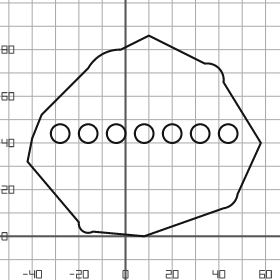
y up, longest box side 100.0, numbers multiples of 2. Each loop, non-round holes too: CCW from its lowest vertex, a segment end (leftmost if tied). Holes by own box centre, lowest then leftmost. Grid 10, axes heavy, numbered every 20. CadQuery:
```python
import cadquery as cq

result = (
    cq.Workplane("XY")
    .moveTo(8.0, 0.0)
    .lineTo(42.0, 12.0)
    .threePointArc((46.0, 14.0), (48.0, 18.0))
    .lineTo(58.0, 40.0)
    .lineTo(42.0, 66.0)
    .threePointArc((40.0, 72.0), (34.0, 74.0))
    .lineTo(10.0, 86.0)
    .lineTo(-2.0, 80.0)
    .threePointArc((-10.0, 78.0), (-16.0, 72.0))
    .lineTo(-36.0, 52.0)
    .lineTo(-40.0, 42.0)
    .lineTo(-42.0, 32.0)
    .lineTo(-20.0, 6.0)
    .threePointArc((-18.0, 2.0), (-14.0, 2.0))
    .close()
    .moveTo(-28.0, 44.0)
    .circle(4.0)
    .moveTo(-16.0, 44.0)
    .circle(4.0)
    .moveTo(-4.0, 44.0)
    .circle(4.0)
    .moveTo(8.0, 44.0)
    .circle(4.0)
    .moveTo(20.0, 44.0)
    .circle(4.0)
    .moveTo(32.0, 44.0)
    .circle(4.0)
    .moveTo(44.0, 44.0)
    .circle(4.0)
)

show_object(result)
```